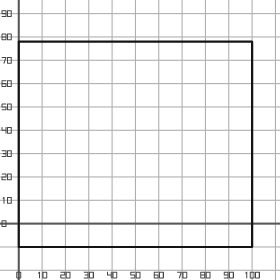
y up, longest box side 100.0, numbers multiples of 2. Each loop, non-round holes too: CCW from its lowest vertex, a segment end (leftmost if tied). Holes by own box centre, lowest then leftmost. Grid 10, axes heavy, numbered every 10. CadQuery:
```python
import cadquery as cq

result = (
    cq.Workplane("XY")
    .moveTo(0.0, -10.0)
    .lineTo(100.0, -10.0)
    .lineTo(100.0, 78.0)
    .lineTo(0.0, 78.0)
    .close()
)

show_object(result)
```